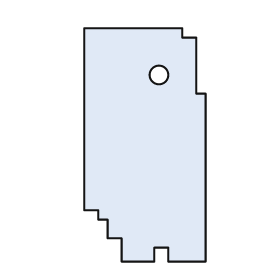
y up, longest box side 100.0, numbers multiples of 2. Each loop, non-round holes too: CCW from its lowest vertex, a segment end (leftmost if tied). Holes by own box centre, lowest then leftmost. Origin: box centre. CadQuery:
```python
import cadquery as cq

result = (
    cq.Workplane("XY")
    .moveTo(-10.0, -50.0)
    .lineTo(4.0, -50.0)
    .lineTo(4.0, -44.0)
    .lineTo(10.0, -44.0)
    .lineTo(10.0, -50.0)
    .lineTo(26.0, -50.0)
    .lineTo(26.0, 22.0)
    .lineTo(22.0, 22.0)
    .lineTo(22.0, 46.0)
    .lineTo(16.0, 46.0)
    .lineTo(16.0, 50.0)
    .lineTo(-26.0, 50.0)
    .lineTo(-26.0, -28.0)
    .lineTo(-20.0, -28.0)
    .lineTo(-20.0, -32.0)
    .lineTo(-16.0, -32.0)
    .lineTo(-16.0, -40.0)
    .lineTo(-10.0, -40.0)
    .close()
    .moveTo(6.0, 30.0)
    .circle(4.0)
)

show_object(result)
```